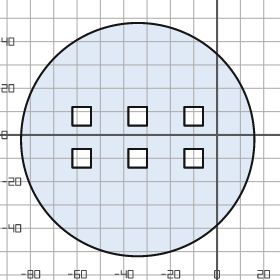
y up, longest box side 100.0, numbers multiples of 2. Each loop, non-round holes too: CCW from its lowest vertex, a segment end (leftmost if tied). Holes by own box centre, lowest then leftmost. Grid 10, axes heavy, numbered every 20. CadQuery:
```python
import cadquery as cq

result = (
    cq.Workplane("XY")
    .moveTo(-34.0, -2.0)
    .circle(50.0)
    .moveTo(-62.0, -14.0)
    .lineTo(-54.0, -14.0)
    .lineTo(-54.0, -6.0)
    .lineTo(-62.0, -6.0)
    .close()
    .moveTo(-38.0, -14.0)
    .lineTo(-30.0, -14.0)
    .lineTo(-30.0, -6.0)
    .lineTo(-38.0, -6.0)
    .close()
    .moveTo(-14.0, -14.0)
    .lineTo(-6.0, -14.0)
    .lineTo(-6.0, -6.0)
    .lineTo(-14.0, -6.0)
    .close()
    .moveTo(-62.0, 4.0)
    .lineTo(-54.0, 4.0)
    .lineTo(-54.0, 12.0)
    .lineTo(-62.0, 12.0)
    .close()
    .moveTo(-38.0, 4.0)
    .lineTo(-30.0, 4.0)
    .lineTo(-30.0, 12.0)
    .lineTo(-38.0, 12.0)
    .close()
    .moveTo(-14.0, 4.0)
    .lineTo(-6.0, 4.0)
    .lineTo(-6.0, 12.0)
    .lineTo(-14.0, 12.0)
    .close()
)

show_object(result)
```